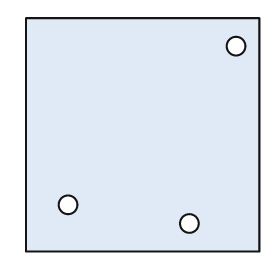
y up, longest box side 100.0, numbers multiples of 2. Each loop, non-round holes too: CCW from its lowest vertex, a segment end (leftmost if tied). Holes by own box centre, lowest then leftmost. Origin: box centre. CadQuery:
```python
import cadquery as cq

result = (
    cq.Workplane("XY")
    .moveTo(-50.0, -50.0)
    .lineTo(50.0, -50.0)
    .lineTo(50.0, 50.0)
    .lineTo(-50.0, 50.0)
    .close()
    .moveTo(20.0, -38.0)
    .circle(4.0)
    .moveTo(-32.0, -30.0)
    .circle(4.0)
    .moveTo(40.0, 38.0)
    .circle(4.0)
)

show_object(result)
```